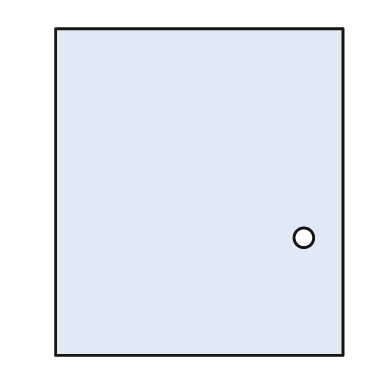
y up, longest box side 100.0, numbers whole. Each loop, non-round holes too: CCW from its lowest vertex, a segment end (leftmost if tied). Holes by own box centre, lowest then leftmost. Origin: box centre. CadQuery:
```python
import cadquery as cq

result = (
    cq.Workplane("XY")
    .moveTo(-44.0, -50.0)
    .lineTo(44.0, -50.0)
    .lineTo(44.0, 50.0)
    .lineTo(-44.0, 50.0)
    .close()
    .moveTo(32.0, -14.0)
    .circle(3.0)
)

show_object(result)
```